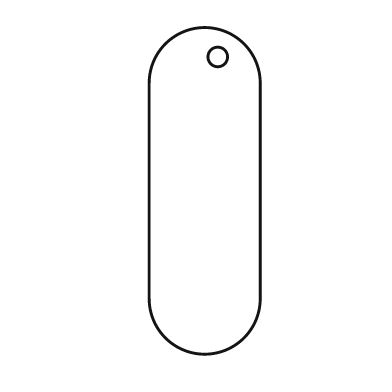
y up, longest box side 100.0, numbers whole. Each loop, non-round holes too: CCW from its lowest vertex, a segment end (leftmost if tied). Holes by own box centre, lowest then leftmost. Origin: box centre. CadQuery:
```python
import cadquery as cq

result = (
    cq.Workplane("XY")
    .moveTo(-17.0, -33.0)
    .threePointArc((0.0, -50.0), (17.0, -33.0))
    .lineTo(17.0, 33.0)
    .threePointArc((0.0, 50.0), (-17.0, 33.0))
    .close()
    .moveTo(4.0, 41.0)
    .circle(3.0)
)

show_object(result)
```